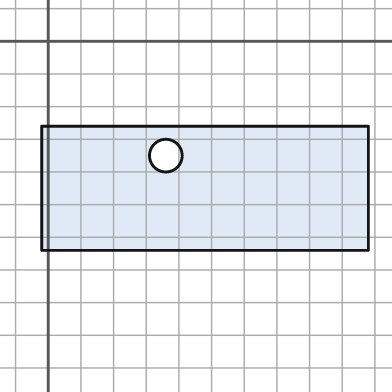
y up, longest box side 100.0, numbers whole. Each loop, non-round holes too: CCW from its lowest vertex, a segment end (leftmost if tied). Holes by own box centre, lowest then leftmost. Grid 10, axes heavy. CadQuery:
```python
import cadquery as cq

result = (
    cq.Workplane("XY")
    .moveTo(-2.0, -64.0)
    .lineTo(98.0, -64.0)
    .lineTo(98.0, -26.0)
    .lineTo(-2.0, -26.0)
    .close()
    .moveTo(36.0, -35.0)
    .circle(5.0)
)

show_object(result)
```